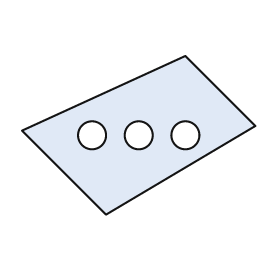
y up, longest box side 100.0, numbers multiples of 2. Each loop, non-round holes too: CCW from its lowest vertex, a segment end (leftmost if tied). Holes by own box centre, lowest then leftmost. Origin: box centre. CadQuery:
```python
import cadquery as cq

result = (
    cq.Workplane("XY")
    .moveTo(-14.0, -34.0)
    .lineTo(50.0, 4.0)
    .lineTo(20.0, 34.0)
    .lineTo(-50.0, 2.0)
    .close()
    .moveTo(-20.0, 0.0)
    .circle(6.0)
    .moveTo(0.0, 0.0)
    .circle(6.0)
    .moveTo(20.0, 0.0)
    .circle(6.0)
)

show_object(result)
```